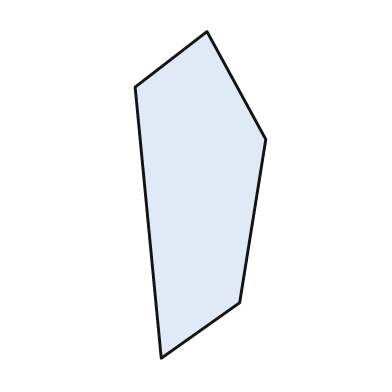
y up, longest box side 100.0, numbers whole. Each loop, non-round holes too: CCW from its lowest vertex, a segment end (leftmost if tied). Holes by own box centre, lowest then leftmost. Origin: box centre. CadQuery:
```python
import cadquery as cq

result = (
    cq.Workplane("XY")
    .moveTo(-12.0, -50.0)
    .lineTo(12.0, -33.0)
    .lineTo(20.0, 17.0)
    .lineTo(2.0, 50.0)
    .lineTo(-20.0, 33.0)
    .close()
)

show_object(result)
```